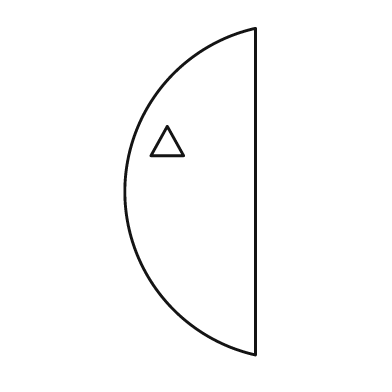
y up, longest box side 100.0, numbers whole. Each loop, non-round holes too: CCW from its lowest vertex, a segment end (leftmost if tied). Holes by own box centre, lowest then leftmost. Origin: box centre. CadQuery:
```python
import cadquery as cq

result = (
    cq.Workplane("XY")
    .moveTo(20.0, -50.0)
    .lineTo(20.0, 50.0)
    .threePointArc((-20.0, 0.0), (20.0, -50.0))
    .close()
    .moveTo(-12.0, 11.0)
    .lineTo(-2.0, 11.0)
    .lineTo(-7.0, 20.0)
    .close()
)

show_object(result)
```